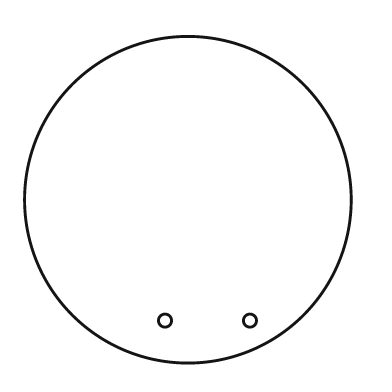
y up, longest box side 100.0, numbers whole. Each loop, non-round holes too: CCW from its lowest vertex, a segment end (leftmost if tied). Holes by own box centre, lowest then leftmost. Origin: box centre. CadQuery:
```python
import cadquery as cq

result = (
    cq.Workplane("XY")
    .moveTo(0.0, 0.0)
    .circle(50.0)
    .moveTo(-7.0, -37.0)
    .circle(2.0)
    .moveTo(19.0, -37.0)
    .circle(2.0)
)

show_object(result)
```